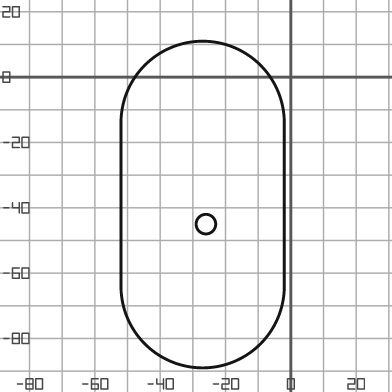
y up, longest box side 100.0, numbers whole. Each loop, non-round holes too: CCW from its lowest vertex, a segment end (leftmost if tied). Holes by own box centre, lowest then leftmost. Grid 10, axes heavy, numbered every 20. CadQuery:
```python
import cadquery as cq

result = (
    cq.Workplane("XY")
    .moveTo(-52.0, -64.0)
    .threePointArc((-27.0, -89.0), (-2.0, -64.0))
    .lineTo(-2.0, -14.0)
    .threePointArc((-27.0, 11.0), (-52.0, -14.0))
    .close()
    .moveTo(-26.0, -45.0)
    .circle(3.0)
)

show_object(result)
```